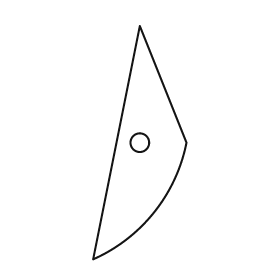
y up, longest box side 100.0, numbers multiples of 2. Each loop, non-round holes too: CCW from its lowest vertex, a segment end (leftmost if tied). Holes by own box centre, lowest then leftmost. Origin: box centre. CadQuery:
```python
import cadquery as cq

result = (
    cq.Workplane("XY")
    .moveTo(-20.0, -50.0)
    .threePointArc((6.0, -30.0), (20.0, 0.0))
    .lineTo(0.0, 50.0)
    .close()
    .moveTo(0.0, 0.0)
    .circle(4.0)
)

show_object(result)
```